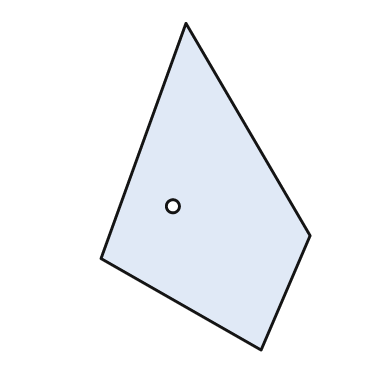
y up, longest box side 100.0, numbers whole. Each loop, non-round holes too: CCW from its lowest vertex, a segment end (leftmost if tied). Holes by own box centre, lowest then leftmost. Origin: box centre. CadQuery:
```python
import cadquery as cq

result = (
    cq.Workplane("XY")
    .moveTo(17.0, -50.0)
    .lineTo(32.0, -15.0)
    .lineTo(-6.0, 50.0)
    .lineTo(-32.0, -22.0)
    .close()
    .moveTo(-10.0, -6.0)
    .circle(2.0)
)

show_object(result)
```